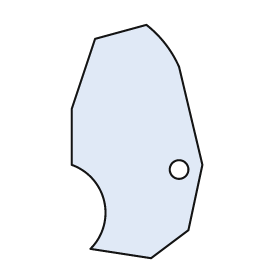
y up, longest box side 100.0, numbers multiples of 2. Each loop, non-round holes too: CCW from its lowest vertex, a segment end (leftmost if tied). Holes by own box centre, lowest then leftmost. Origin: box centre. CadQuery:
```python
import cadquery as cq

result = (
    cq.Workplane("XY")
    .moveTo(6.0, -50.0)
    .lineTo(22.0, -38.0)
    .lineTo(28.0, -10.0)
    .lineTo(18.0, 32.0)
    .threePointArc((12.0, 42.0), (4.0, 50.0))
    .lineTo(-18.0, 44.0)
    .lineTo(-28.0, 14.0)
    .lineTo(-28.0, -10.0)
    .threePointArc((-14.0, -26.0), (-20.0, -46.0))
    .close()
    .moveTo(18.0, -12.0)
    .circle(4.0)
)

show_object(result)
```